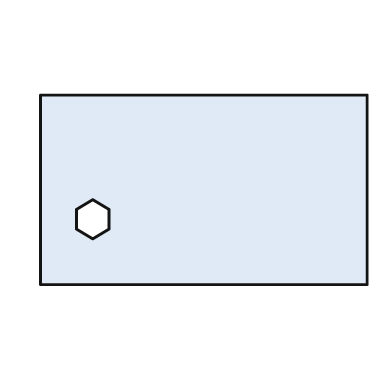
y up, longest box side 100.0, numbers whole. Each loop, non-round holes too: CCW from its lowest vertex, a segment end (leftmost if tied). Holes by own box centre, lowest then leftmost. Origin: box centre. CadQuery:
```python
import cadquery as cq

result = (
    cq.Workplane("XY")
    .moveTo(-50.0, -29.0)
    .lineTo(50.0, -29.0)
    .lineTo(50.0, 29.0)
    .lineTo(-50.0, 29.0)
    .close()
    .moveTo(-34.0, -15.0)
    .lineTo(-29.0, -12.0)
    .lineTo(-29.0, -6.0)
    .lineTo(-34.0, -3.0)
    .lineTo(-39.0, -6.0)
    .lineTo(-39.0, -12.0)
    .close()
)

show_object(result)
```